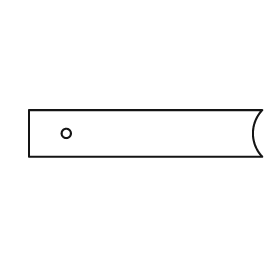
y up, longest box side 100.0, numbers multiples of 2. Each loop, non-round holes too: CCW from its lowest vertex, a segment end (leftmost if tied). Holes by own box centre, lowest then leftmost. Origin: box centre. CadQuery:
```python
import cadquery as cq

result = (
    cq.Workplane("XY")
    .moveTo(-50.0, -10.0)
    .lineTo(50.0, -10.0)
    .threePointArc((46.0, 0.0), (50.0, 10.0))
    .lineTo(-50.0, 10.0)
    .close()
    .moveTo(-34.0, 0.0)
    .circle(2.0)
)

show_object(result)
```